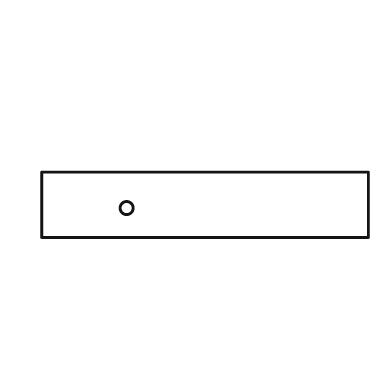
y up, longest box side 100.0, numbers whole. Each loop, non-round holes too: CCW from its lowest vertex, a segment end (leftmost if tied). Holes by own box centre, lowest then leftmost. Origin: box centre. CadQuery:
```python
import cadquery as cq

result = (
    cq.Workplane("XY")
    .moveTo(-50.0, -10.0)
    .lineTo(50.0, -10.0)
    .lineTo(50.0, 10.0)
    .lineTo(-50.0, 10.0)
    .close()
    .moveTo(-24.0, -1.0)
    .circle(2.0)
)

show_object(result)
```